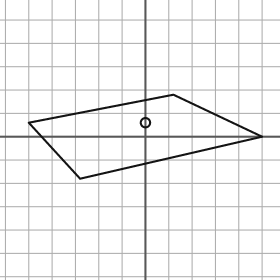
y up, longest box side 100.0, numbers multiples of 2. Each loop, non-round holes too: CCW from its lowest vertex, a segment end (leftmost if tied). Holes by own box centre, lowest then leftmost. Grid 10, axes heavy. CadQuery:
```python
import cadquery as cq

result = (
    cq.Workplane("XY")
    .moveTo(-28.0, -18.0)
    .lineTo(50.0, 0.0)
    .lineTo(12.0, 18.0)
    .lineTo(-50.0, 6.0)
    .close()
    .moveTo(0.0, 6.0)
    .circle(2.0)
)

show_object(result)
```